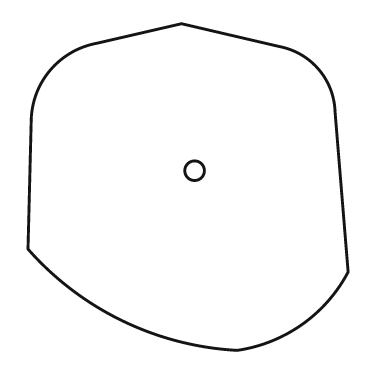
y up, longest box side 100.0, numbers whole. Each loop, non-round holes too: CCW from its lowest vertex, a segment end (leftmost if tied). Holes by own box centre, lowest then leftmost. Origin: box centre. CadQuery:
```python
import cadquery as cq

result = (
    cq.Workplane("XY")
    .moveTo(15.0, -50.0)
    .threePointArc((35.0, -42.0), (49.0, -26.0))
    .lineTo(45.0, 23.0)
    .threePointArc((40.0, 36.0), (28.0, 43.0))
    .lineTo(-2.0, 50.0)
    .lineTo(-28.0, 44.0)
    .threePointArc((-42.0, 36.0), (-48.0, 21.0))
    .lineTo(-49.0, -19.0)
    .threePointArc((-20.0, -41.0), (15.0, -50.0))
    .close()
    .moveTo(2.0, 5.0)
    .circle(3.0)
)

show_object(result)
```